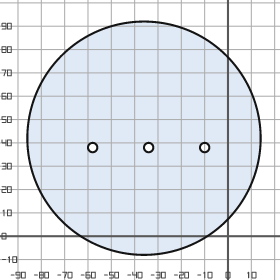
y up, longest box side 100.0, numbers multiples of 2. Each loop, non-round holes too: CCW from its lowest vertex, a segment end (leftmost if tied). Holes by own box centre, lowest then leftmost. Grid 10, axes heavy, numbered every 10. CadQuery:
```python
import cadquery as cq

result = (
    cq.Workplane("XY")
    .moveTo(-36.0, 42.0)
    .circle(50.0)
    .moveTo(-58.0, 38.0)
    .circle(2.0)
    .moveTo(-34.0, 38.0)
    .circle(2.0)
    .moveTo(-10.0, 38.0)
    .circle(2.0)
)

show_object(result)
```